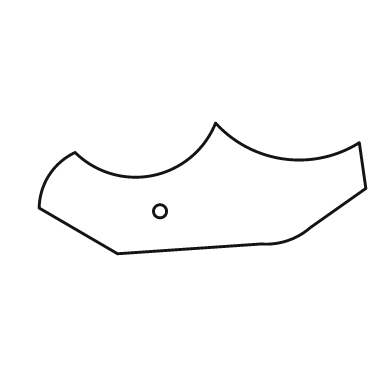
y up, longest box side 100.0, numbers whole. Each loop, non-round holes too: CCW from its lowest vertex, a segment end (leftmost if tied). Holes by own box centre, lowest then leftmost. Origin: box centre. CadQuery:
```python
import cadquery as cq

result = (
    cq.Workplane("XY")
    .moveTo(-26.0, -20.0)
    .lineTo(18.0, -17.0)
    .threePointArc((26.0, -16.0), (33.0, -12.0))
    .lineTo(50.0, 0.0)
    .lineTo(48.0, 14.0)
    .threePointArc((25.0, 9.0), (4.0, 20.0))
    .threePointArc((-15.0, 4.0), (-39.0, 11.0))
    .threePointArc((-47.0, 4.0), (-50.0, -6.0))
    .close()
    .moveTo(-13.0, -7.0)
    .circle(2.0)
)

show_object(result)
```